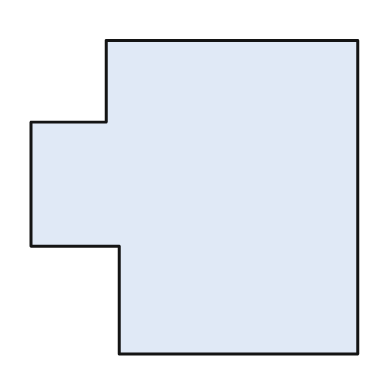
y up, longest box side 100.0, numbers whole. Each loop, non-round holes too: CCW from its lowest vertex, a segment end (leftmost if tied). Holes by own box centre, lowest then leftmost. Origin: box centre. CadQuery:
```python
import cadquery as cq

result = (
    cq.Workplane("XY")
    .moveTo(-23.0, -48.0)
    .lineTo(50.0, -48.0)
    .lineTo(50.0, 48.0)
    .lineTo(-27.0, 48.0)
    .lineTo(-27.0, 23.0)
    .lineTo(-50.0, 23.0)
    .lineTo(-50.0, -15.0)
    .lineTo(-23.0, -15.0)
    .close()
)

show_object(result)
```